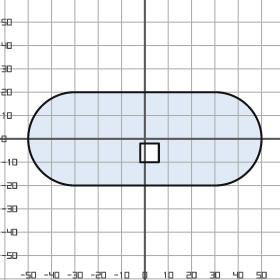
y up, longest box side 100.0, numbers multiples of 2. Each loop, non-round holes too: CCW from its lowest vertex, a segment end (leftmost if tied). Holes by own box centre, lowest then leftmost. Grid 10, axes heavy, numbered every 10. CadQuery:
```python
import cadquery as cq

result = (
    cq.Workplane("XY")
    .moveTo(-30.0, -20.0)
    .lineTo(30.0, -20.0)
    .threePointArc((50.0, 0.0), (30.0, 20.0))
    .lineTo(-30.0, 20.0)
    .threePointArc((-50.0, 0.0), (-30.0, -20.0))
    .close()
    .moveTo(-2.0, -10.0)
    .lineTo(6.0, -10.0)
    .lineTo(6.0, -2.0)
    .lineTo(-2.0, -2.0)
    .close()
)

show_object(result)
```